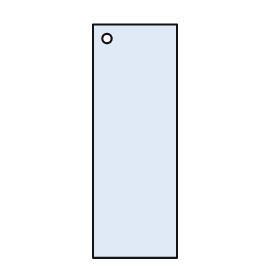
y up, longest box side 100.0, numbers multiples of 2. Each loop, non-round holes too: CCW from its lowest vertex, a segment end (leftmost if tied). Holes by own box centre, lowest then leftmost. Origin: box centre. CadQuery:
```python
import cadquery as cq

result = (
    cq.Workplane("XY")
    .moveTo(-18.0, -50.0)
    .lineTo(18.0, -50.0)
    .lineTo(18.0, 50.0)
    .lineTo(-18.0, 50.0)
    .close()
    .moveTo(-12.0, 44.0)
    .circle(2.0)
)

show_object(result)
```